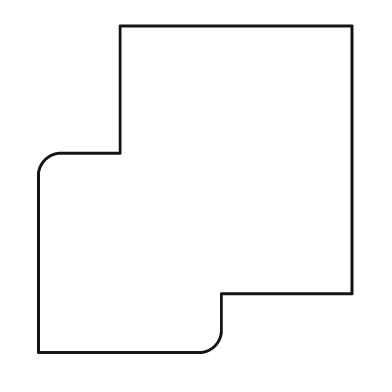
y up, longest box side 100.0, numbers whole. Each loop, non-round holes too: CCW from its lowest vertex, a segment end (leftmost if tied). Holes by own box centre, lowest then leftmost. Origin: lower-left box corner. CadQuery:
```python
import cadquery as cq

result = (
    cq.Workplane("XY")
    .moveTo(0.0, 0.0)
    .lineTo(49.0, 0.0)
    .threePointArc((54.0, 2.0), (56.0, 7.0))
    .lineTo(56.0, 18.0)
    .lineTo(96.0, 18.0)
    .lineTo(96.0, 100.0)
    .lineTo(25.0, 100.0)
    .lineTo(25.0, 61.0)
    .lineTo(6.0, 61.0)
    .threePointArc((2.0, 59.0), (0.0, 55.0))
    .close()
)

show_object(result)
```